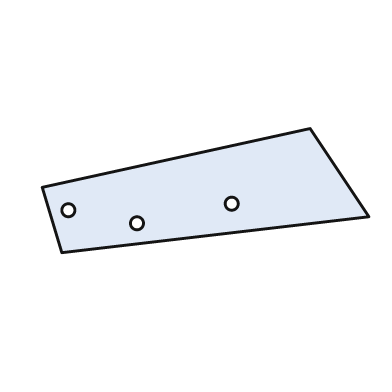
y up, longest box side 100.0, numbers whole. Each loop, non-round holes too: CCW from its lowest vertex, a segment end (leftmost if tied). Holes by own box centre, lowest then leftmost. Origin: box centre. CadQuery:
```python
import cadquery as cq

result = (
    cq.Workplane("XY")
    .moveTo(-44.0, -19.0)
    .lineTo(50.0, -8.0)
    .lineTo(32.0, 19.0)
    .lineTo(-50.0, 1.0)
    .close()
    .moveTo(-21.0, -10.0)
    .circle(2.0)
    .moveTo(-42.0, -6.0)
    .circle(2.0)
    .moveTo(8.0, -4.0)
    .circle(2.0)
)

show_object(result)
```